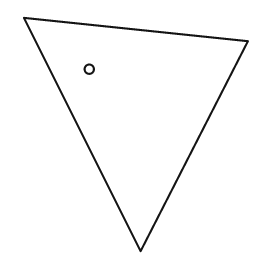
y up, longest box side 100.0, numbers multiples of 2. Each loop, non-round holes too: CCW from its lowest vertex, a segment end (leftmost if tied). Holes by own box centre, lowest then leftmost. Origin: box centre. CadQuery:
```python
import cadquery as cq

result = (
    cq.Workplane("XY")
    .moveTo(2.0, -50.0)
    .lineTo(48.0, 40.0)
    .lineTo(-48.0, 50.0)
    .close()
    .moveTo(-20.0, 28.0)
    .circle(2.0)
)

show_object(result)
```